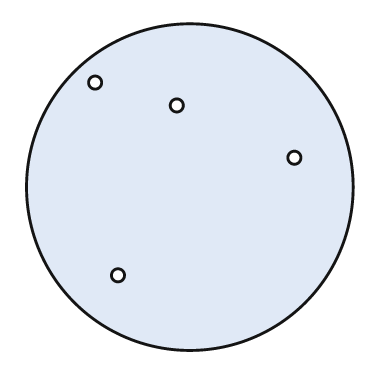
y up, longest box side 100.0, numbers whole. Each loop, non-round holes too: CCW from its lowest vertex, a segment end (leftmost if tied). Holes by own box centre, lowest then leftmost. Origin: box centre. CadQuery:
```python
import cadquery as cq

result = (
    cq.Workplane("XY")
    .moveTo(0.0, 0.0)
    .circle(50.0)
    .moveTo(-22.0, -27.0)
    .circle(2.0)
    .moveTo(32.0, 9.0)
    .circle(2.0)
    .moveTo(-4.0, 25.0)
    .circle(2.0)
    .moveTo(-29.0, 32.0)
    .circle(2.0)
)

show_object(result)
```